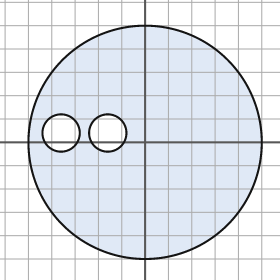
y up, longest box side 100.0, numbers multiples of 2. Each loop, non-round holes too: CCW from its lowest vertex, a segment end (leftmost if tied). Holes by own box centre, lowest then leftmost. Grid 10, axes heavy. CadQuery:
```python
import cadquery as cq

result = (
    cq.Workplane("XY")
    .moveTo(0.0, 0.0)
    .circle(50.0)
    .moveTo(-36.0, 4.0)
    .circle(8.0)
    .moveTo(-16.0, 4.0)
    .circle(8.0)
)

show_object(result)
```